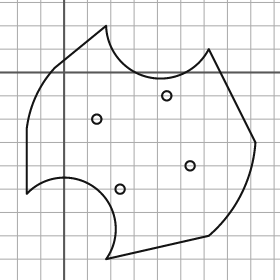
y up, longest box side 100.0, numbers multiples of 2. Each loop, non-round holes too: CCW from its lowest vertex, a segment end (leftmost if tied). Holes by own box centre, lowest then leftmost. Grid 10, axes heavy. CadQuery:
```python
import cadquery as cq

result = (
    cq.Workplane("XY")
    .moveTo(18.0, -80.0)
    .lineTo(62.0, -70.0)
    .threePointArc((76.0, -52.0), (82.0, -30.0))
    .lineTo(62.0, 10.0)
    .threePointArc((36.0, -2.0), (18.0, 20.0))
    .lineTo(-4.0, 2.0)
    .threePointArc((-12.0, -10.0), (-16.0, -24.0))
    .lineTo(-16.0, -52.0)
    .threePointArc((14.0, -50.0), (18.0, -80.0))
    .close()
    .moveTo(24.0, -50.0)
    .circle(2.0)
    .moveTo(54.0, -40.0)
    .circle(2.0)
    .moveTo(14.0, -20.0)
    .circle(2.0)
    .moveTo(44.0, -10.0)
    .circle(2.0)
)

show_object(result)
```